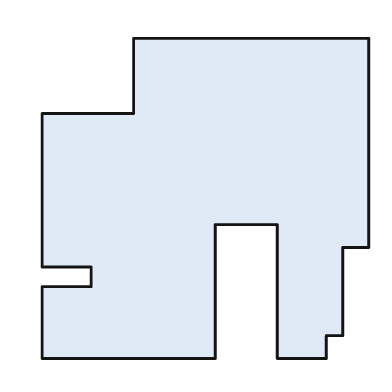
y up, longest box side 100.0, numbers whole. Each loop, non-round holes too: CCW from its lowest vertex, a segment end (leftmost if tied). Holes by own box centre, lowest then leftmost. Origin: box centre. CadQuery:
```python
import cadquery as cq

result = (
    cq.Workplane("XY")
    .moveTo(-50.0, -49.0)
    .lineTo(3.0, -49.0)
    .lineTo(3.0, -8.0)
    .lineTo(22.0, -8.0)
    .lineTo(22.0, -49.0)
    .lineTo(37.0, -49.0)
    .lineTo(37.0, -42.0)
    .lineTo(42.0, -42.0)
    .lineTo(42.0, -15.0)
    .lineTo(50.0, -15.0)
    .lineTo(50.0, 49.0)
    .lineTo(-22.0, 49.0)
    .lineTo(-22.0, 26.0)
    .lineTo(-50.0, 26.0)
    .lineTo(-50.0, -21.0)
    .lineTo(-35.0, -21.0)
    .lineTo(-35.0, -27.0)
    .lineTo(-50.0, -27.0)
    .close()
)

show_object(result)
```